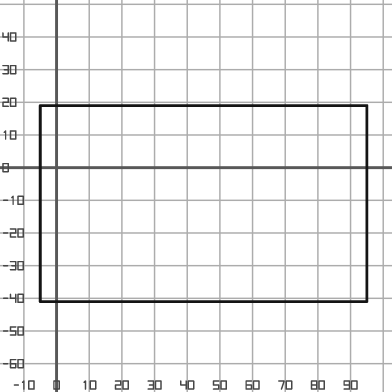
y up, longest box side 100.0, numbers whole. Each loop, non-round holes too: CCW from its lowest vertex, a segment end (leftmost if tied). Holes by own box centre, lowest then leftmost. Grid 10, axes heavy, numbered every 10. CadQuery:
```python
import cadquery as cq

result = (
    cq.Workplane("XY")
    .moveTo(-5.0, -41.0)
    .lineTo(95.0, -41.0)
    .lineTo(95.0, 19.0)
    .lineTo(-5.0, 19.0)
    .close()
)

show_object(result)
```